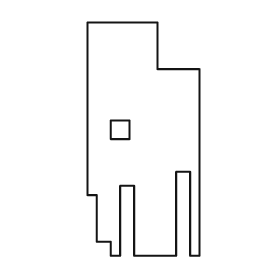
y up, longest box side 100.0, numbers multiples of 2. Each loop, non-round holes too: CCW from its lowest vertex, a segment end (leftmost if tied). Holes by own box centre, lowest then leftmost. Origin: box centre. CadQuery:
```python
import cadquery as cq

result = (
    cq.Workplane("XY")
    .moveTo(-14.0, -50.0)
    .lineTo(-10.0, -50.0)
    .lineTo(-10.0, -20.0)
    .lineTo(-4.0, -20.0)
    .lineTo(-4.0, -50.0)
    .lineTo(14.0, -50.0)
    .lineTo(14.0, -14.0)
    .lineTo(20.0, -14.0)
    .lineTo(20.0, -50.0)
    .lineTo(24.0, -50.0)
    .lineTo(24.0, 30.0)
    .lineTo(6.0, 30.0)
    .lineTo(6.0, 50.0)
    .lineTo(-24.0, 50.0)
    .lineTo(-24.0, -24.0)
    .lineTo(-20.0, -24.0)
    .lineTo(-20.0, -44.0)
    .lineTo(-14.0, -44.0)
    .close()
    .moveTo(-14.0, 0.0)
    .lineTo(-6.0, 0.0)
    .lineTo(-6.0, 8.0)
    .lineTo(-14.0, 8.0)
    .close()
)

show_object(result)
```